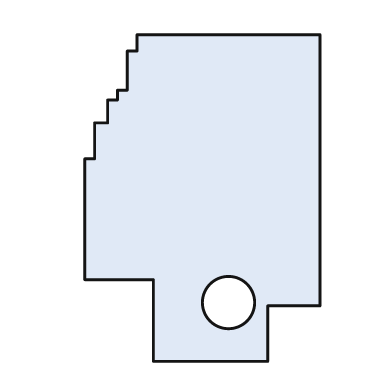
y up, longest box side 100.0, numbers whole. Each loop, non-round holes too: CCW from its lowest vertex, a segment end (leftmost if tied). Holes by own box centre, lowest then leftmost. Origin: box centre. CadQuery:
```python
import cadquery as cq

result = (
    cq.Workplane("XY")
    .moveTo(-15.0, -50.0)
    .lineTo(20.0, -50.0)
    .lineTo(20.0, -33.0)
    .lineTo(36.0, -33.0)
    .lineTo(36.0, 50.0)
    .lineTo(-20.0, 50.0)
    .lineTo(-20.0, 45.0)
    .lineTo(-23.0, 45.0)
    .lineTo(-23.0, 33.0)
    .lineTo(-26.0, 33.0)
    .lineTo(-26.0, 30.0)
    .lineTo(-29.0, 30.0)
    .lineTo(-29.0, 23.0)
    .lineTo(-33.0, 23.0)
    .lineTo(-33.0, 12.0)
    .lineTo(-36.0, 12.0)
    .lineTo(-36.0, -25.0)
    .lineTo(-15.0, -25.0)
    .close()
    .moveTo(8.0, -32.0)
    .circle(8.0)
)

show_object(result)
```